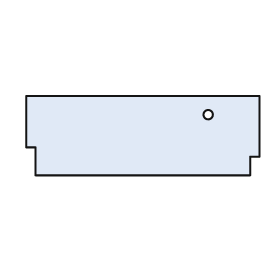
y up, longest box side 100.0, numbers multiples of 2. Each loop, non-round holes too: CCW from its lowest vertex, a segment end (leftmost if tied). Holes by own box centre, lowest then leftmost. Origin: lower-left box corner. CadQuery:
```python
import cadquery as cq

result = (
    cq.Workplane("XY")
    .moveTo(4.0, 0.0)
    .lineTo(96.0, 0.0)
    .lineTo(96.0, 8.0)
    .lineTo(100.0, 8.0)
    .lineTo(100.0, 34.0)
    .lineTo(0.0, 34.0)
    .lineTo(0.0, 12.0)
    .lineTo(4.0, 12.0)
    .close()
    .moveTo(78.0, 26.0)
    .circle(2.0)
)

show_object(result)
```